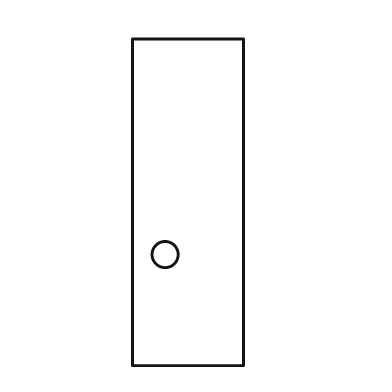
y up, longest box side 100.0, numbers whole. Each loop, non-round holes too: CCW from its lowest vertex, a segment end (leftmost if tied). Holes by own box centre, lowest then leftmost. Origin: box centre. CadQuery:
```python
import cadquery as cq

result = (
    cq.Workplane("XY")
    .moveTo(-17.0, -50.0)
    .lineTo(17.0, -50.0)
    .lineTo(17.0, 50.0)
    .lineTo(-17.0, 50.0)
    .close()
    .moveTo(-7.0, -16.0)
    .circle(4.0)
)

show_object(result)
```